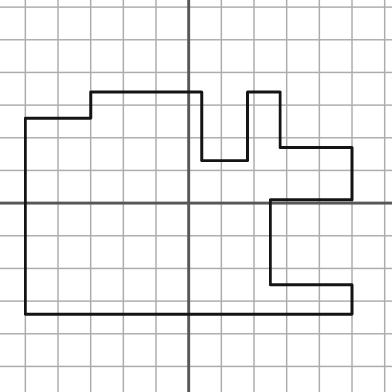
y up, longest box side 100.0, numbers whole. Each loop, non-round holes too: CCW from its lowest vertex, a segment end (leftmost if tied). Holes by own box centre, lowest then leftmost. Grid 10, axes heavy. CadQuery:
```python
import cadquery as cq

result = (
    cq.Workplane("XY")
    .moveTo(-50.0, -34.0)
    .lineTo(50.0, -34.0)
    .lineTo(50.0, -25.0)
    .lineTo(25.0, -25.0)
    .lineTo(25.0, 1.0)
    .lineTo(50.0, 1.0)
    .lineTo(50.0, 17.0)
    .lineTo(28.0, 17.0)
    .lineTo(28.0, 34.0)
    .lineTo(18.0, 34.0)
    .lineTo(18.0, 13.0)
    .lineTo(4.0, 13.0)
    .lineTo(4.0, 34.0)
    .lineTo(-30.0, 34.0)
    .lineTo(-30.0, 26.0)
    .lineTo(-50.0, 26.0)
    .close()
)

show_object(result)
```